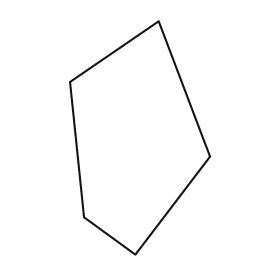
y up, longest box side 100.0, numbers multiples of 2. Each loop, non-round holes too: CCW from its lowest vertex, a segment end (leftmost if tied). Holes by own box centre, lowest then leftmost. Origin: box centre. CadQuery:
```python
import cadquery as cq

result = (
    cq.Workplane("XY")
    .moveTo(-2.0, -50.0)
    .lineTo(30.0, -8.0)
    .lineTo(8.0, 50.0)
    .lineTo(-30.0, 24.0)
    .lineTo(-24.0, -34.0)
    .close()
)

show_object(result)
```